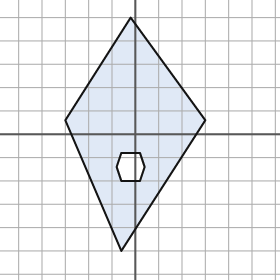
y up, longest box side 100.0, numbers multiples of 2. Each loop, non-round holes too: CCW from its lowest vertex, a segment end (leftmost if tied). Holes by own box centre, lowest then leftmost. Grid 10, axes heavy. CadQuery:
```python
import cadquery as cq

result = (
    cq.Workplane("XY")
    .moveTo(-6.0, -50.0)
    .lineTo(30.0, 6.0)
    .lineTo(-2.0, 50.0)
    .lineTo(-30.0, 6.0)
    .close()
    .moveTo(-6.0, -20.0)
    .lineTo(2.0, -20.0)
    .lineTo(4.0, -14.0)
    .lineTo(2.0, -8.0)
    .lineTo(-6.0, -8.0)
    .lineTo(-8.0, -14.0)
    .close()
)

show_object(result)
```